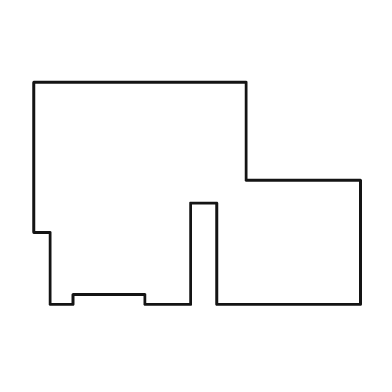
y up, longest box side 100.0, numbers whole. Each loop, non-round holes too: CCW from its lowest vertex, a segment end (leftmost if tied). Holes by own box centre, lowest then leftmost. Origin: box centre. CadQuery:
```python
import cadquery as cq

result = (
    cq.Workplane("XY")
    .moveTo(-45.0, -34.0)
    .lineTo(-38.0, -34.0)
    .lineTo(-38.0, -31.0)
    .lineTo(-16.0, -31.0)
    .lineTo(-16.0, -34.0)
    .lineTo(-2.0, -34.0)
    .lineTo(-2.0, -3.0)
    .lineTo(6.0, -3.0)
    .lineTo(6.0, -34.0)
    .lineTo(50.0, -34.0)
    .lineTo(50.0, 4.0)
    .lineTo(15.0, 4.0)
    .lineTo(15.0, 34.0)
    .lineTo(-50.0, 34.0)
    .lineTo(-50.0, -12.0)
    .lineTo(-45.0, -12.0)
    .close()
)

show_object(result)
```